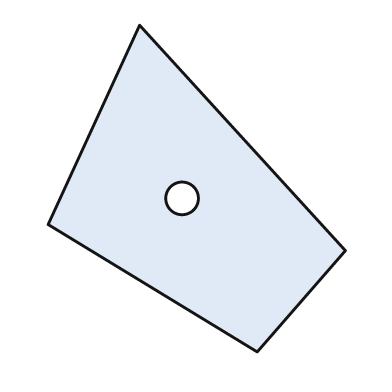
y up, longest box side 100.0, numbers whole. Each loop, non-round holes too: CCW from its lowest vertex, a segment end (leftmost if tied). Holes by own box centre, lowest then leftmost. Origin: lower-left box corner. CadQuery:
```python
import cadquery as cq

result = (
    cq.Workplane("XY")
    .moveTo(64.0, 0.0)
    .lineTo(91.0, 31.0)
    .lineTo(28.0, 100.0)
    .lineTo(0.0, 39.0)
    .close()
    .moveTo(41.0, 47.0)
    .circle(5.0)
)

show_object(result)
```